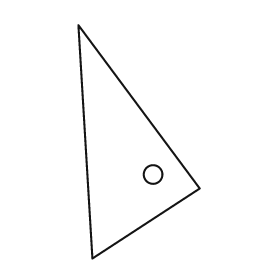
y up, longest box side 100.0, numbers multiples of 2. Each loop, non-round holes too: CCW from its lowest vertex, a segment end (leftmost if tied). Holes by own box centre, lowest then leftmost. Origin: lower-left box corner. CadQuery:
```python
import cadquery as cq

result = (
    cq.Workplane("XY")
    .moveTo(6.0, 0.0)
    .lineTo(52.0, 30.0)
    .lineTo(0.0, 100.0)
    .close()
    .moveTo(32.0, 36.0)
    .circle(4.0)
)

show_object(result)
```